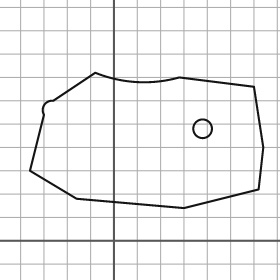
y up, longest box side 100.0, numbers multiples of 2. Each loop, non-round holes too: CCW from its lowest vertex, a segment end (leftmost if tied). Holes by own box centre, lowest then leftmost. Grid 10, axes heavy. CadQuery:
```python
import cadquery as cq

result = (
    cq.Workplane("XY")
    .moveTo(30.0, 14.0)
    .lineTo(62.0, 22.0)
    .lineTo(64.0, 40.0)
    .lineTo(60.0, 66.0)
    .lineTo(28.0, 70.0)
    .threePointArc((10.0, 68.0), (-8.0, 72.0))
    .lineTo(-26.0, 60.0)
    .threePointArc((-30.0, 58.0), (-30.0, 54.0))
    .lineTo(-36.0, 30.0)
    .lineTo(-16.0, 18.0)
    .close()
    .moveTo(38.0, 48.0)
    .circle(4.0)
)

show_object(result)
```